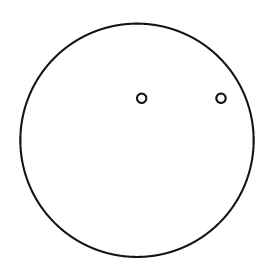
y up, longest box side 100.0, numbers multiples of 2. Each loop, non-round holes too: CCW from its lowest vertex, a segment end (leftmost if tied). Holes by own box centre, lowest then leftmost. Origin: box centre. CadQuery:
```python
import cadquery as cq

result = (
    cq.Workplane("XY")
    .moveTo(0.0, 0.0)
    .circle(50.0)
    .moveTo(2.0, 18.0)
    .circle(2.0)
    .moveTo(36.0, 18.0)
    .circle(2.0)
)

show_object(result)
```